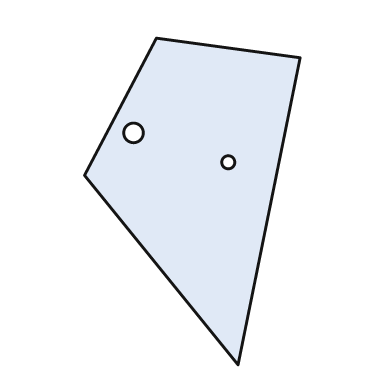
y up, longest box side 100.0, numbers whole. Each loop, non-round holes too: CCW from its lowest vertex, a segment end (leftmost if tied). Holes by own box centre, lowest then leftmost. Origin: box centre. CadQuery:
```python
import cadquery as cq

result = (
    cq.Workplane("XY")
    .moveTo(14.0, -50.0)
    .lineTo(33.0, 44.0)
    .lineTo(-11.0, 50.0)
    .lineTo(-33.0, 8.0)
    .close()
    .moveTo(11.0, 12.0)
    .circle(2.0)
    .moveTo(-18.0, 21.0)
    .circle(3.0)
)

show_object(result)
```